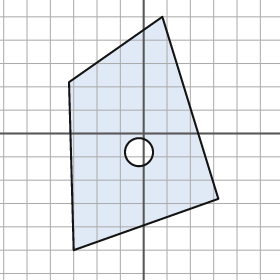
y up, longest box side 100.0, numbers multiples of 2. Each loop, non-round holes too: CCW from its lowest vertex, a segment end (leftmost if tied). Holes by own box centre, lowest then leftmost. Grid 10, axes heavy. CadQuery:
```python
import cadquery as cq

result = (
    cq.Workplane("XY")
    .moveTo(-30.0, -50.0)
    .lineTo(32.0, -28.0)
    .lineTo(8.0, 50.0)
    .lineTo(-32.0, 22.0)
    .close()
    .moveTo(-2.0, -8.0)
    .circle(6.0)
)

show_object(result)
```